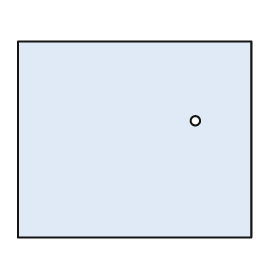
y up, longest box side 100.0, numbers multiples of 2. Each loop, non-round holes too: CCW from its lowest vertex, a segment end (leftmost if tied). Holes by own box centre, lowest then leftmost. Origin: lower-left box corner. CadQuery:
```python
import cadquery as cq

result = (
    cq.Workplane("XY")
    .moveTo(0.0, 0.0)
    .lineTo(100.0, 0.0)
    .lineTo(100.0, 84.0)
    .lineTo(0.0, 84.0)
    .close()
    .moveTo(76.0, 50.0)
    .circle(2.0)
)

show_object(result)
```